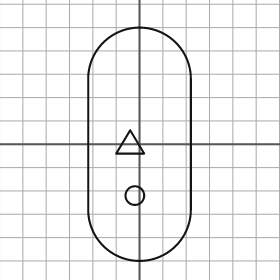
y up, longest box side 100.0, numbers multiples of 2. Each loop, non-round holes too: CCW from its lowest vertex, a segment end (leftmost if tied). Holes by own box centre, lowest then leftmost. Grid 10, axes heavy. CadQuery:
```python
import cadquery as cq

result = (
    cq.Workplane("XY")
    .moveTo(-22.0, -28.0)
    .threePointArc((0.0, -50.0), (22.0, -28.0))
    .lineTo(22.0, 28.0)
    .threePointArc((0.0, 50.0), (-22.0, 28.0))
    .close()
    .moveTo(-2.0, -22.0)
    .circle(4.0)
    .moveTo(-10.0, -4.0)
    .lineTo(2.0, -4.0)
    .lineTo(-4.0, 6.0)
    .close()
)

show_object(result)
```